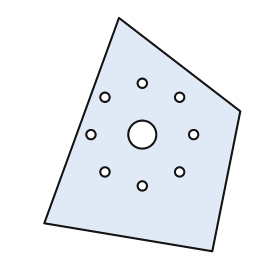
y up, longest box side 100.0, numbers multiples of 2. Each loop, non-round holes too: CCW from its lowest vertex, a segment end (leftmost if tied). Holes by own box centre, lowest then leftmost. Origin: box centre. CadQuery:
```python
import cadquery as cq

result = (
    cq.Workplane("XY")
    .moveTo(30.0, -50.0)
    .lineTo(42.0, 10.0)
    .lineTo(-10.0, 50.0)
    .lineTo(-42.0, -38.0)
    .close()
    .moveTo(0.0, -22.0)
    .circle(2.0)
    .moveTo(-16.0, -16.0)
    .circle(2.0)
    .moveTo(16.0, -16.0)
    .circle(2.0)
    .moveTo(-22.0, 0.0)
    .circle(2.0)
    .moveTo(0.0, 0.0)
    .circle(6.0)
    .moveTo(22.0, 0.0)
    .circle(2.0)
    .moveTo(-16.0, 16.0)
    .circle(2.0)
    .moveTo(16.0, 16.0)
    .circle(2.0)
    .moveTo(0.0, 22.0)
    .circle(2.0)
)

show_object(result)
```